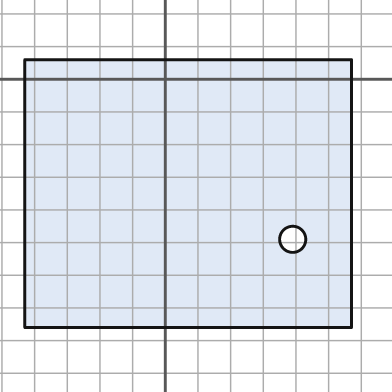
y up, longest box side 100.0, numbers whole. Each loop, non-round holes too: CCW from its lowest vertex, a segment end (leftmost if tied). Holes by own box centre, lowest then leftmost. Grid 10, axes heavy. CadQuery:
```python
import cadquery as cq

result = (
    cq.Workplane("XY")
    .moveTo(-43.0, -76.0)
    .lineTo(57.0, -76.0)
    .lineTo(57.0, 6.0)
    .lineTo(-43.0, 6.0)
    .close()
    .moveTo(39.0, -49.0)
    .circle(4.0)
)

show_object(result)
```